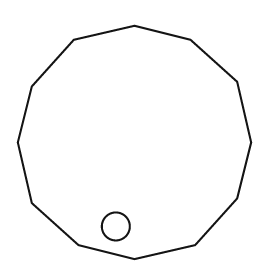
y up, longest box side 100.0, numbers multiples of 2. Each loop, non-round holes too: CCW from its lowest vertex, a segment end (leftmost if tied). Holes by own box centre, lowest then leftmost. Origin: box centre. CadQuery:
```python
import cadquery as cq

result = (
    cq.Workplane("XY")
    .moveTo(0.0, -50.0)
    .lineTo(26.0, -44.0)
    .lineTo(44.0, -24.0)
    .lineTo(50.0, 0.0)
    .lineTo(44.0, 26.0)
    .lineTo(24.0, 44.0)
    .lineTo(0.0, 50.0)
    .lineTo(-26.0, 44.0)
    .lineTo(-44.0, 24.0)
    .lineTo(-50.0, 0.0)
    .lineTo(-44.0, -26.0)
    .lineTo(-24.0, -44.0)
    .close()
    .moveTo(-8.0, -36.0)
    .circle(6.0)
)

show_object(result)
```